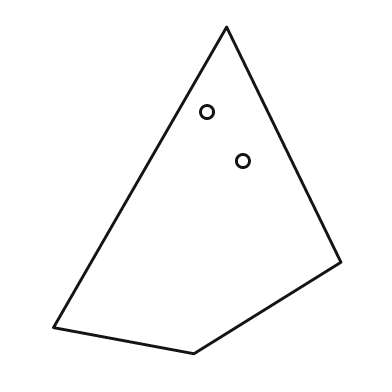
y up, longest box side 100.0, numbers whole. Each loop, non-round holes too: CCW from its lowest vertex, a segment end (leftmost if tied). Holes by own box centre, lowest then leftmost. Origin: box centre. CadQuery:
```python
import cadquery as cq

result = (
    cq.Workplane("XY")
    .moveTo(-1.0, -50.0)
    .lineTo(44.0, -22.0)
    .lineTo(9.0, 50.0)
    .lineTo(-44.0, -42.0)
    .close()
    .moveTo(14.0, 9.0)
    .circle(2.0)
    .moveTo(3.0, 24.0)
    .circle(2.0)
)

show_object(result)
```